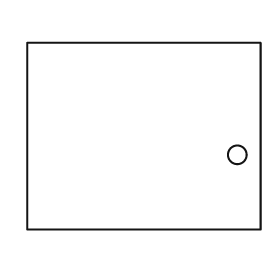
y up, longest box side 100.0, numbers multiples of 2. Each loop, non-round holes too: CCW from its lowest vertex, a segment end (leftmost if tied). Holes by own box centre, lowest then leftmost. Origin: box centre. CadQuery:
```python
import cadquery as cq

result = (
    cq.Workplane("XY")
    .moveTo(-50.0, -40.0)
    .lineTo(50.0, -40.0)
    .lineTo(50.0, 40.0)
    .lineTo(-50.0, 40.0)
    .close()
    .moveTo(40.0, -8.0)
    .circle(4.0)
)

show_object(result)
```